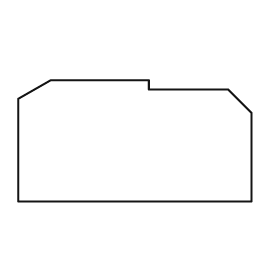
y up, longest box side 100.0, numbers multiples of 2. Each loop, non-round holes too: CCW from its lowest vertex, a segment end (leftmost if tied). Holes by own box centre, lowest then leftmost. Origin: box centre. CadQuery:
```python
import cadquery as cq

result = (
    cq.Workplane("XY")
    .moveTo(-50.0, -26.0)
    .lineTo(50.0, -26.0)
    .lineTo(50.0, 12.0)
    .lineTo(40.0, 22.0)
    .lineTo(6.0, 22.0)
    .lineTo(6.0, 26.0)
    .lineTo(-36.0, 26.0)
    .lineTo(-50.0, 18.0)
    .close()
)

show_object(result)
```